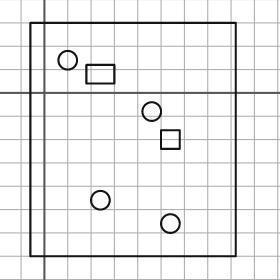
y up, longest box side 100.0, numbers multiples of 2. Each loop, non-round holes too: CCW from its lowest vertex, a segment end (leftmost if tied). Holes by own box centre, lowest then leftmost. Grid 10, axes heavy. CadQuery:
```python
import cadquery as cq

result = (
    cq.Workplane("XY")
    .moveTo(-6.0, -70.0)
    .lineTo(82.0, -70.0)
    .lineTo(82.0, 30.0)
    .lineTo(-6.0, 30.0)
    .close()
    .moveTo(54.0, -56.0)
    .circle(4.0)
    .moveTo(24.0, -46.0)
    .circle(4.0)
    .moveTo(50.0, -24.0)
    .lineTo(58.0, -24.0)
    .lineTo(58.0, -16.0)
    .lineTo(50.0, -16.0)
    .close()
    .moveTo(46.0, -8.0)
    .circle(4.0)
    .moveTo(18.0, 4.0)
    .lineTo(30.0, 4.0)
    .lineTo(30.0, 12.0)
    .lineTo(18.0, 12.0)
    .close()
    .moveTo(10.0, 14.0)
    .circle(4.0)
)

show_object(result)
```